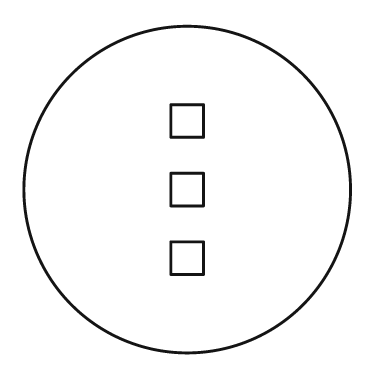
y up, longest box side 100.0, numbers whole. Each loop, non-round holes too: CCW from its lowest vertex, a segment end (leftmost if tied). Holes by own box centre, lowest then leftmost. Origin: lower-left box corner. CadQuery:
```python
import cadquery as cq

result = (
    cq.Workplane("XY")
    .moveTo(50.0, 50.0)
    .circle(50.0)
    .moveTo(45.0, 24.0)
    .lineTo(55.0, 24.0)
    .lineTo(55.0, 34.0)
    .lineTo(45.0, 34.0)
    .close()
    .moveTo(45.0, 45.0)
    .lineTo(55.0, 45.0)
    .lineTo(55.0, 55.0)
    .lineTo(45.0, 55.0)
    .close()
    .moveTo(45.0, 66.0)
    .lineTo(55.0, 66.0)
    .lineTo(55.0, 76.0)
    .lineTo(45.0, 76.0)
    .close()
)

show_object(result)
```